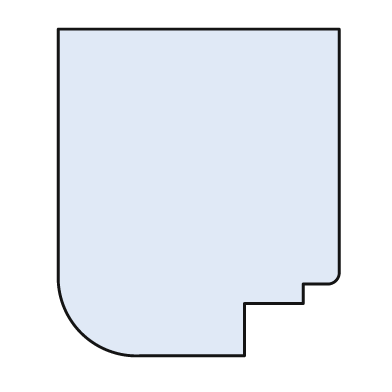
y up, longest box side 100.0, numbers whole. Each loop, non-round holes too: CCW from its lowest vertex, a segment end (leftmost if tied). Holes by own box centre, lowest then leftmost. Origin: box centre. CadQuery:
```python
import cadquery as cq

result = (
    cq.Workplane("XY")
    .moveTo(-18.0, -50.0)
    .lineTo(14.0, -50.0)
    .lineTo(14.0, -34.0)
    .lineTo(32.0, -34.0)
    .lineTo(32.0, -28.0)
    .lineTo(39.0, -28.0)
    .threePointArc((42.0, -27.0), (43.0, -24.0))
    .lineTo(43.0, 50.0)
    .lineTo(-43.0, 50.0)
    .lineTo(-43.0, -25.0)
    .threePointArc((-36.0, -43.0), (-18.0, -50.0))
    .close()
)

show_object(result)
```